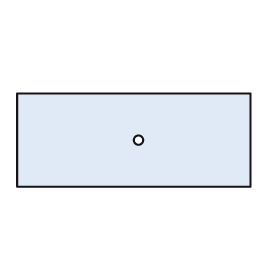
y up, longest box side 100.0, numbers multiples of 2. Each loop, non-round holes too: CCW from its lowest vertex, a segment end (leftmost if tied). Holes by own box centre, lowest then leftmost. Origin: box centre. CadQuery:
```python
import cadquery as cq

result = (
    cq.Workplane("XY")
    .moveTo(-50.0, -20.0)
    .lineTo(50.0, -20.0)
    .lineTo(50.0, 20.0)
    .lineTo(-50.0, 20.0)
    .close()
    .moveTo(2.0, 0.0)
    .circle(2.0)
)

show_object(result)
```